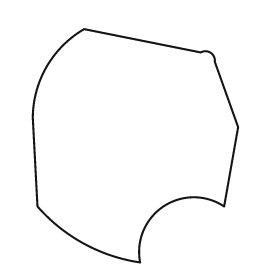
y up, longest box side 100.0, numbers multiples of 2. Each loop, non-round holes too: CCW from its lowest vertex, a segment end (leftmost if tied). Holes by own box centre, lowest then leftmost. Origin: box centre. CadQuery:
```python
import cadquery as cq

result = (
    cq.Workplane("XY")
    .moveTo(2.0, -50.0)
    .threePointArc((12.0, -26.0), (38.0, -26.0))
    .lineTo(44.0, 8.0)
    .lineTo(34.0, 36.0)
    .threePointArc((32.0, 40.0), (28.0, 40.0))
    .lineTo(-22.0, 50.0)
    .threePointArc((-38.0, 34.0), (-44.0, 12.0))
    .lineTo(-42.0, -26.0)
    .threePointArc((-22.0, -42.0), (2.0, -50.0))
    .close()
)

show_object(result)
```